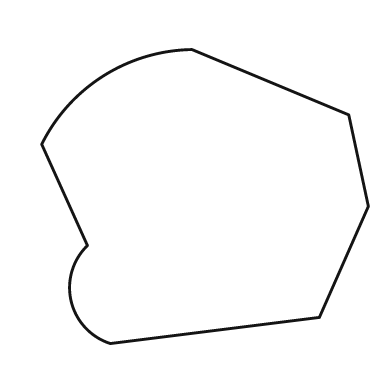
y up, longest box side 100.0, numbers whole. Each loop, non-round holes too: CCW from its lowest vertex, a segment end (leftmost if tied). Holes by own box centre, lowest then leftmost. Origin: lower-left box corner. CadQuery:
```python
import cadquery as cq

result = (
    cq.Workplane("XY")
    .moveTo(21.0, 0.0)
    .lineTo(85.0, 8.0)
    .lineTo(100.0, 42.0)
    .lineTo(94.0, 70.0)
    .lineTo(46.0, 90.0)
    .threePointArc((19.0, 82.0), (0.0, 61.0))
    .lineTo(14.0, 30.0)
    .threePointArc((9.0, 13.0), (21.0, 0.0))
    .close()
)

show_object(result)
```